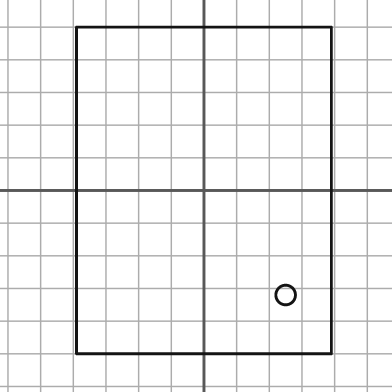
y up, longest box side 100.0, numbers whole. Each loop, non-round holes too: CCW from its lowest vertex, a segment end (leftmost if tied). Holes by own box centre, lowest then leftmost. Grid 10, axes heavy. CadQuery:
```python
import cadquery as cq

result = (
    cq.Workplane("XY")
    .moveTo(-39.0, -50.0)
    .lineTo(39.0, -50.0)
    .lineTo(39.0, 50.0)
    .lineTo(-39.0, 50.0)
    .close()
    .moveTo(25.0, -32.0)
    .circle(3.0)
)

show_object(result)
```